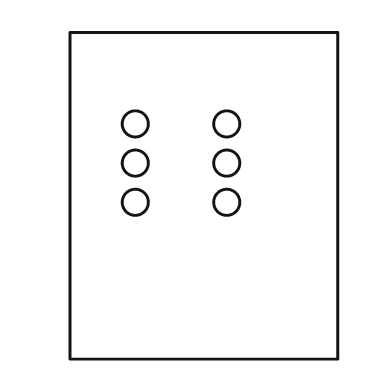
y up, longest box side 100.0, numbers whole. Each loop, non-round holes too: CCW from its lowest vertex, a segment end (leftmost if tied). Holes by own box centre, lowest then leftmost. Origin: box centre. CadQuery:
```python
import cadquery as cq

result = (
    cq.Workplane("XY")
    .moveTo(-41.0, -50.0)
    .lineTo(41.0, -50.0)
    .lineTo(41.0, 50.0)
    .lineTo(-41.0, 50.0)
    .close()
    .moveTo(-21.0, -2.0)
    .circle(4.0)
    .moveTo(7.0, -2.0)
    .circle(4.0)
    .moveTo(-21.0, 10.0)
    .circle(4.0)
    .moveTo(7.0, 10.0)
    .circle(4.0)
    .moveTo(-21.0, 22.0)
    .circle(4.0)
    .moveTo(7.0, 22.0)
    .circle(4.0)
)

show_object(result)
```